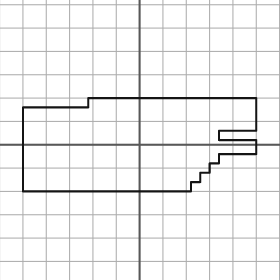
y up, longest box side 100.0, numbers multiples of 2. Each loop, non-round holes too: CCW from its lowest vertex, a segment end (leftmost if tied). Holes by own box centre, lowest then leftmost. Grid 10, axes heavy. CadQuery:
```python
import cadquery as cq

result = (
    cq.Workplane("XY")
    .moveTo(-50.0, -20.0)
    .lineTo(22.0, -20.0)
    .lineTo(22.0, -16.0)
    .lineTo(26.0, -16.0)
    .lineTo(26.0, -12.0)
    .lineTo(30.0, -12.0)
    .lineTo(30.0, -8.0)
    .lineTo(34.0, -8.0)
    .lineTo(34.0, -4.0)
    .lineTo(50.0, -4.0)
    .lineTo(50.0, 2.0)
    .lineTo(34.0, 2.0)
    .lineTo(34.0, 6.0)
    .lineTo(50.0, 6.0)
    .lineTo(50.0, 20.0)
    .lineTo(-22.0, 20.0)
    .lineTo(-22.0, 16.0)
    .lineTo(-50.0, 16.0)
    .close()
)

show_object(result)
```